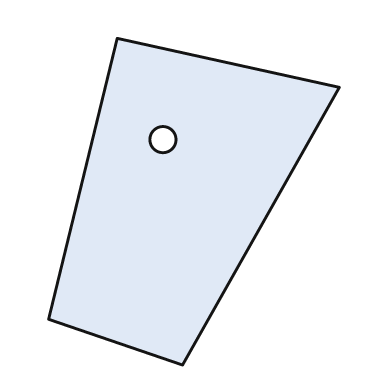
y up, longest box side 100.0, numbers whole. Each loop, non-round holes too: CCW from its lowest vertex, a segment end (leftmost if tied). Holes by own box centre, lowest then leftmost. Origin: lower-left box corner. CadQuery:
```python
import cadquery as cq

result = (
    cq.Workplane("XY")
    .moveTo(41.0, 0.0)
    .lineTo(89.0, 85.0)
    .lineTo(21.0, 100.0)
    .lineTo(0.0, 14.0)
    .close()
    .moveTo(35.0, 69.0)
    .circle(4.0)
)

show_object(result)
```